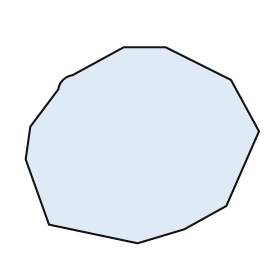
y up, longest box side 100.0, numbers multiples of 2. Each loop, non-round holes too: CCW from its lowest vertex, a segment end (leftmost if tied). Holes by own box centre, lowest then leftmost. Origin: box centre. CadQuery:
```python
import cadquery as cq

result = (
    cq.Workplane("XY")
    .moveTo(-2.0, -42.0)
    .lineTo(18.0, -36.0)
    .lineTo(36.0, -26.0)
    .lineTo(50.0, 6.0)
    .lineTo(38.0, 28.0)
    .lineTo(10.0, 42.0)
    .lineTo(-8.0, 42.0)
    .lineTo(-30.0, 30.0)
    .threePointArc((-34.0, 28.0), (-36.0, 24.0))
    .lineTo(-48.0, 8.0)
    .lineTo(-50.0, -6.0)
    .lineTo(-40.0, -34.0)
    .close()
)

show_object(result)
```